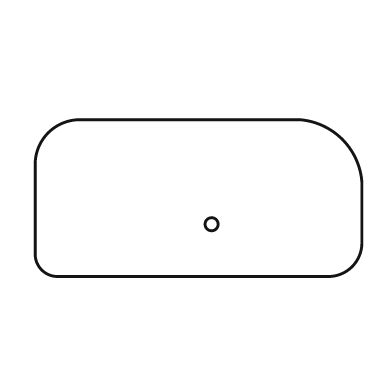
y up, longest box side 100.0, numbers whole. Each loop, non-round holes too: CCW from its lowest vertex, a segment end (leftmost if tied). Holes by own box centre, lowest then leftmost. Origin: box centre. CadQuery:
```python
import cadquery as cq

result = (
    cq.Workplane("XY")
    .moveTo(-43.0, -24.0)
    .lineTo(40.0, -24.0)
    .threePointArc((47.0, -21.0), (50.0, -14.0))
    .lineTo(50.0, 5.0)
    .threePointArc((44.0, 18.0), (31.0, 24.0))
    .lineTo(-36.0, 24.0)
    .threePointArc((-46.0, 20.0), (-50.0, 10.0))
    .lineTo(-50.0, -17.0)
    .threePointArc((-48.0, -22.0), (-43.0, -24.0))
    .close()
    .moveTo(4.0, -8.0)
    .circle(2.0)
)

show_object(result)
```